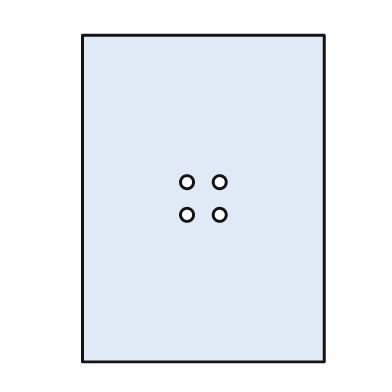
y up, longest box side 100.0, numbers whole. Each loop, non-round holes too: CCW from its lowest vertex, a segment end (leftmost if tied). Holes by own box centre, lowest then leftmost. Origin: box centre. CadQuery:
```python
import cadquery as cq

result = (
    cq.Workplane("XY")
    .moveTo(-37.0, -50.0)
    .lineTo(37.0, -50.0)
    .lineTo(37.0, 50.0)
    .lineTo(-37.0, 50.0)
    .close()
    .moveTo(-5.0, -5.0)
    .circle(2.0)
    .moveTo(5.0, -5.0)
    .circle(2.0)
    .moveTo(-5.0, 5.0)
    .circle(2.0)
    .moveTo(5.0, 5.0)
    .circle(2.0)
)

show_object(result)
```